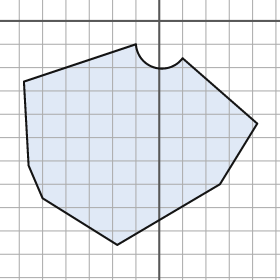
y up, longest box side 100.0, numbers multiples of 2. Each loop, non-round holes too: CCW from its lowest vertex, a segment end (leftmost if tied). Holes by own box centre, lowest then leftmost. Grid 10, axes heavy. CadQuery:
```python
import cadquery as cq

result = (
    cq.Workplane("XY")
    .moveTo(-18.0, -96.0)
    .lineTo(26.0, -70.0)
    .lineTo(42.0, -44.0)
    .lineTo(10.0, -16.0)
    .threePointArc((-2.0, -20.0), (-10.0, -10.0))
    .lineTo(-58.0, -26.0)
    .lineTo(-56.0, -62.0)
    .lineTo(-50.0, -76.0)
    .close()
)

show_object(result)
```